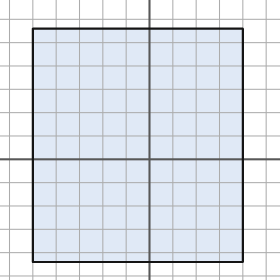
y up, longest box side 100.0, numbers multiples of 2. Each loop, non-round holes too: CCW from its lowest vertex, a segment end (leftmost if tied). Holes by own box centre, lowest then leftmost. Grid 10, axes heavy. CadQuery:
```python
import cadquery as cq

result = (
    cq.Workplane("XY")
    .moveTo(-50.0, -44.0)
    .lineTo(40.0, -44.0)
    .lineTo(40.0, 56.0)
    .lineTo(-50.0, 56.0)
    .close()
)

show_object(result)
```